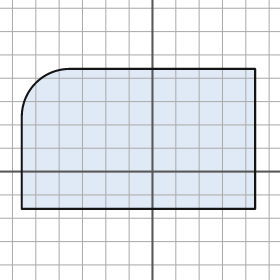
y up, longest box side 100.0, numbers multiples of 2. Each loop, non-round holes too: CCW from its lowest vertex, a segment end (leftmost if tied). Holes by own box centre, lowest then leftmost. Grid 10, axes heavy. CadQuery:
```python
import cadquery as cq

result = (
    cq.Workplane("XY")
    .moveTo(-56.0, -16.0)
    .lineTo(44.0, -16.0)
    .lineTo(44.0, 44.0)
    .lineTo(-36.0, 44.0)
    .threePointArc((-50.0, 38.0), (-56.0, 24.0))
    .close()
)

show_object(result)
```